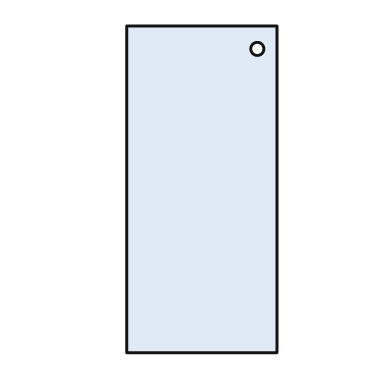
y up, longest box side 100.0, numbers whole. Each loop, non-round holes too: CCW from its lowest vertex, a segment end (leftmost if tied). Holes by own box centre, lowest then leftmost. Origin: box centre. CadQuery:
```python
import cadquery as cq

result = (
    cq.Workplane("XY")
    .moveTo(-23.0, -50.0)
    .lineTo(23.0, -50.0)
    .lineTo(23.0, 50.0)
    .lineTo(-23.0, 50.0)
    .close()
    .moveTo(17.0, 43.0)
    .circle(2.0)
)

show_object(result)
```